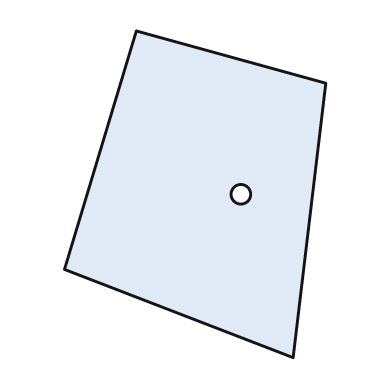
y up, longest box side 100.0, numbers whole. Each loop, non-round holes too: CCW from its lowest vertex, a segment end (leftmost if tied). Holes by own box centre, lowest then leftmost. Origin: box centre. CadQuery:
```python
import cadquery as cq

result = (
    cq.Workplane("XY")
    .moveTo(30.0, -50.0)
    .lineTo(40.0, 34.0)
    .lineTo(-18.0, 50.0)
    .lineTo(-40.0, -23.0)
    .close()
    .moveTo(14.0, 0.0)
    .circle(3.0)
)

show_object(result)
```